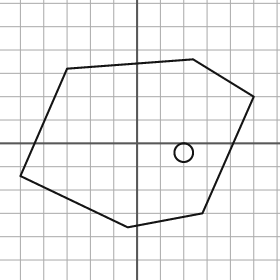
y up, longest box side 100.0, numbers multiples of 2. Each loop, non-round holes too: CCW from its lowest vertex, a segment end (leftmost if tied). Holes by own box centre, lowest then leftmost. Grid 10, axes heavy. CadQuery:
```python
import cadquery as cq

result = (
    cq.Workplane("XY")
    .moveTo(-4.0, -36.0)
    .lineTo(28.0, -30.0)
    .lineTo(50.0, 20.0)
    .lineTo(24.0, 36.0)
    .lineTo(-30.0, 32.0)
    .lineTo(-50.0, -14.0)
    .close()
    .moveTo(20.0, -4.0)
    .circle(4.0)
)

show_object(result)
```